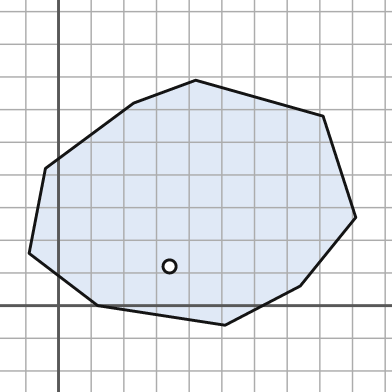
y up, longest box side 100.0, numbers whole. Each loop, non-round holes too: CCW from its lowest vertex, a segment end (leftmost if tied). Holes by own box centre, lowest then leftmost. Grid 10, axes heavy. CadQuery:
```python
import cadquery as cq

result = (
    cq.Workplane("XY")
    .moveTo(51.0, -6.0)
    .lineTo(74.0, 6.0)
    .lineTo(91.0, 27.0)
    .lineTo(81.0, 58.0)
    .lineTo(42.0, 69.0)
    .lineTo(23.0, 62.0)
    .lineTo(-4.0, 42.0)
    .lineTo(-9.0, 16.0)
    .lineTo(12.0, 0.0)
    .close()
    .moveTo(34.0, 12.0)
    .circle(2.0)
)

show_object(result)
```